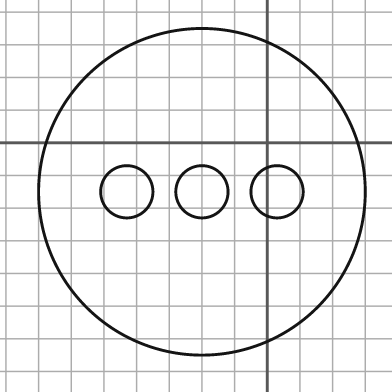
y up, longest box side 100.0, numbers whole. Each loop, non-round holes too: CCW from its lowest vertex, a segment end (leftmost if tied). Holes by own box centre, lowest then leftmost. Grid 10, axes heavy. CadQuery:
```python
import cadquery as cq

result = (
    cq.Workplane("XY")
    .moveTo(-20.0, -15.0)
    .circle(50.0)
    .moveTo(-43.0, -15.0)
    .circle(8.0)
    .moveTo(-20.0, -15.0)
    .circle(8.0)
    .moveTo(3.0, -15.0)
    .circle(8.0)
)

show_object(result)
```